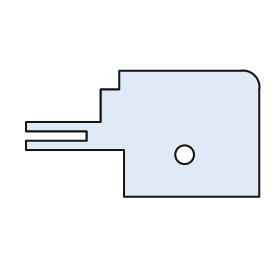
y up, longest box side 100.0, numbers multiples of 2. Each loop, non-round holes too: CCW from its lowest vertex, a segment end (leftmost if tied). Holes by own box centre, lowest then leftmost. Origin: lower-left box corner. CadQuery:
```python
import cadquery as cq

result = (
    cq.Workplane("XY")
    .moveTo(42.0, 0.0)
    .lineTo(100.0, 0.0)
    .lineTo(100.0, 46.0)
    .threePointArc((98.0, 52.0), (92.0, 54.0))
    .lineTo(40.0, 54.0)
    .lineTo(40.0, 46.0)
    .lineTo(32.0, 46.0)
    .lineTo(32.0, 32.0)
    .lineTo(0.0, 32.0)
    .lineTo(0.0, 28.0)
    .lineTo(26.0, 28.0)
    .lineTo(26.0, 24.0)
    .lineTo(0.0, 24.0)
    .lineTo(0.0, 20.0)
    .lineTo(42.0, 20.0)
    .close()
    .moveTo(68.0, 18.0)
    .circle(4.0)
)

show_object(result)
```